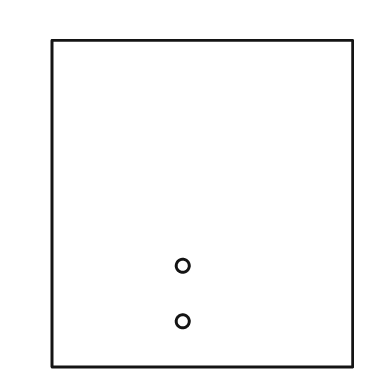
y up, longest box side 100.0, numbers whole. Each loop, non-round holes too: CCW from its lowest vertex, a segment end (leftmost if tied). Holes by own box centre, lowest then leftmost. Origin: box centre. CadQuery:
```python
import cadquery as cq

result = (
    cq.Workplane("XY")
    .moveTo(-46.0, -50.0)
    .lineTo(46.0, -50.0)
    .lineTo(46.0, 50.0)
    .lineTo(-46.0, 50.0)
    .close()
    .moveTo(-6.0, -36.0)
    .circle(2.0)
    .moveTo(-6.0, -19.0)
    .circle(2.0)
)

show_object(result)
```